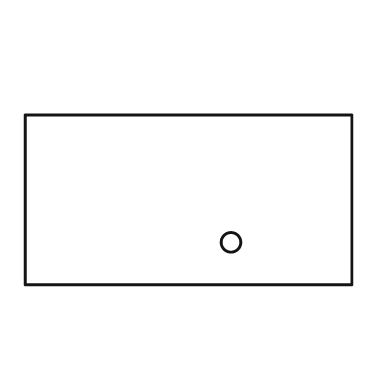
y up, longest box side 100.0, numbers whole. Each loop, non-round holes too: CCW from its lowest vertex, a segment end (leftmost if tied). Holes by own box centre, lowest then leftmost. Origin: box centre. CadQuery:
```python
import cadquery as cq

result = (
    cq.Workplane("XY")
    .moveTo(-50.0, -26.0)
    .lineTo(50.0, -26.0)
    .lineTo(50.0, 26.0)
    .lineTo(-50.0, 26.0)
    .close()
    .moveTo(13.0, -13.0)
    .circle(3.0)
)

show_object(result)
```